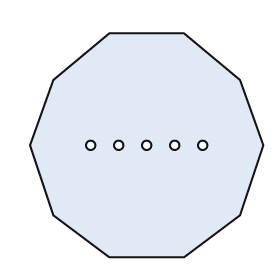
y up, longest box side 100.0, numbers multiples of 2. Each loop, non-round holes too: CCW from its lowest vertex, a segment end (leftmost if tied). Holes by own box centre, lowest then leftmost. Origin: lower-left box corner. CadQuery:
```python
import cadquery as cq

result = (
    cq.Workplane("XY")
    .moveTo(34.0, 0.0)
    .lineTo(66.0, 0.0)
    .lineTo(90.0, 18.0)
    .lineTo(100.0, 48.0)
    .lineTo(90.0, 76.0)
    .lineTo(66.0, 96.0)
    .lineTo(34.0, 96.0)
    .lineTo(10.0, 76.0)
    .lineTo(0.0, 48.0)
    .lineTo(10.0, 18.0)
    .close()
    .moveTo(26.0, 48.0)
    .circle(2.0)
    .moveTo(38.0, 48.0)
    .circle(2.0)
    .moveTo(50.0, 48.0)
    .circle(2.0)
    .moveTo(62.0, 48.0)
    .circle(2.0)
    .moveTo(74.0, 48.0)
    .circle(2.0)
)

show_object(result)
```